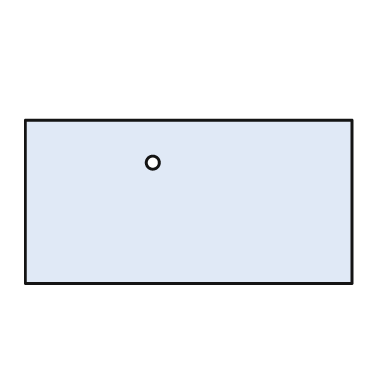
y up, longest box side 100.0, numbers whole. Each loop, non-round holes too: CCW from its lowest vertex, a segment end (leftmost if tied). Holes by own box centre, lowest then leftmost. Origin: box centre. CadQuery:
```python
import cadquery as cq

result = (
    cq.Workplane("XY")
    .moveTo(-50.0, -25.0)
    .lineTo(50.0, -25.0)
    .lineTo(50.0, 25.0)
    .lineTo(-50.0, 25.0)
    .close()
    .moveTo(-11.0, 12.0)
    .circle(2.0)
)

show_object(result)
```